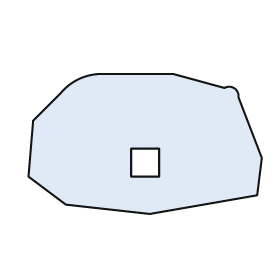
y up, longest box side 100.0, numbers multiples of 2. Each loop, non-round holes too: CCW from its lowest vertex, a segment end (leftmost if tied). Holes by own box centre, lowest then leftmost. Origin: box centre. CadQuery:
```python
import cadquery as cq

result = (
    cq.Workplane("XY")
    .moveTo(2.0, -30.0)
    .lineTo(48.0, -22.0)
    .lineTo(50.0, -6.0)
    .lineTo(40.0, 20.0)
    .threePointArc((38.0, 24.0), (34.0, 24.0))
    .lineTo(12.0, 30.0)
    .lineTo(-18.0, 30.0)
    .threePointArc((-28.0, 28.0), (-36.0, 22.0))
    .lineTo(-48.0, 10.0)
    .lineTo(-50.0, -14.0)
    .lineTo(-34.0, -26.0)
    .close()
    .moveTo(-6.0, -14.0)
    .lineTo(6.0, -14.0)
    .lineTo(6.0, -2.0)
    .lineTo(-6.0, -2.0)
    .close()
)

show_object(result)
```